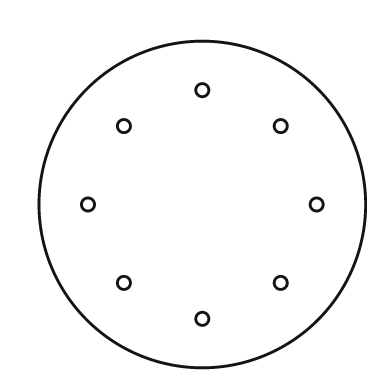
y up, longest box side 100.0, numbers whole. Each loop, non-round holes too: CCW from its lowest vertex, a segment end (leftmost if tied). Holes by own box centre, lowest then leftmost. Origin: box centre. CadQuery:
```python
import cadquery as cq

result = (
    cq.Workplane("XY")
    .moveTo(0.0, 0.0)
    .circle(50.0)
    .moveTo(0.0, -35.0)
    .circle(2.0)
    .moveTo(-24.0, -24.0)
    .circle(2.0)
    .moveTo(24.0, -24.0)
    .circle(2.0)
    .moveTo(-35.0, 0.0)
    .circle(2.0)
    .moveTo(35.0, 0.0)
    .circle(2.0)
    .moveTo(-24.0, 24.0)
    .circle(2.0)
    .moveTo(24.0, 24.0)
    .circle(2.0)
    .moveTo(0.0, 35.0)
    .circle(2.0)
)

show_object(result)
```